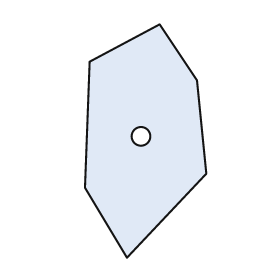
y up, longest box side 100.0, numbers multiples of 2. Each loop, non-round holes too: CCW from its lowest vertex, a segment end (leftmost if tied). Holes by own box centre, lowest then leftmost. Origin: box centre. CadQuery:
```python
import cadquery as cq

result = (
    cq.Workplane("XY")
    .moveTo(-8.0, -50.0)
    .lineTo(26.0, -14.0)
    .lineTo(22.0, 26.0)
    .lineTo(6.0, 50.0)
    .lineTo(-24.0, 34.0)
    .lineTo(-26.0, -20.0)
    .close()
    .moveTo(-2.0, 2.0)
    .circle(4.0)
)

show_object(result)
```